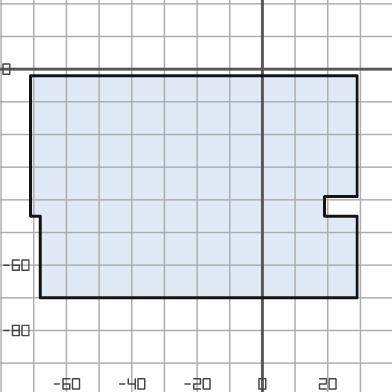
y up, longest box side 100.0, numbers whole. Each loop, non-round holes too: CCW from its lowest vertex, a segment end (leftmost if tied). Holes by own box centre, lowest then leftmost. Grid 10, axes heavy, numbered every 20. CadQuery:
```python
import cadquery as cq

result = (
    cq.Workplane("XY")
    .moveTo(-68.0, -70.0)
    .lineTo(29.0, -70.0)
    .lineTo(29.0, -45.0)
    .lineTo(19.0, -45.0)
    .lineTo(19.0, -39.0)
    .lineTo(29.0, -39.0)
    .lineTo(29.0, -2.0)
    .lineTo(-71.0, -2.0)
    .lineTo(-71.0, -45.0)
    .lineTo(-68.0, -45.0)
    .close()
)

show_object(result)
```